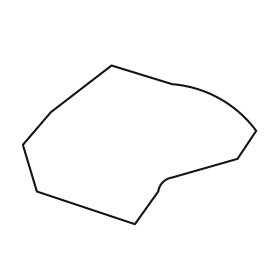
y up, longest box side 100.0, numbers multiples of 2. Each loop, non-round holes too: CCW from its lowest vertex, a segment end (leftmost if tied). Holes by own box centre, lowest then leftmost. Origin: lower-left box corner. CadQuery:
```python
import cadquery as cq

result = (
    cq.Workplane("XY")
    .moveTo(48.0, 0.0)
    .lineTo(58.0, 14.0)
    .threePointArc((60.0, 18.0), (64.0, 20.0))
    .lineTo(92.0, 28.0)
    .lineTo(100.0, 40.0)
    .threePointArc((84.0, 54.0), (64.0, 60.0))
    .lineTo(38.0, 68.0)
    .lineTo(12.0, 48.0)
    .lineTo(0.0, 34.0)
    .lineTo(6.0, 14.0)
    .close()
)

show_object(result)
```